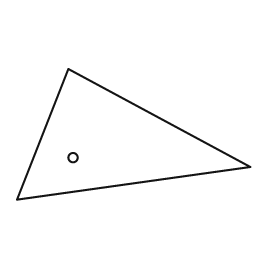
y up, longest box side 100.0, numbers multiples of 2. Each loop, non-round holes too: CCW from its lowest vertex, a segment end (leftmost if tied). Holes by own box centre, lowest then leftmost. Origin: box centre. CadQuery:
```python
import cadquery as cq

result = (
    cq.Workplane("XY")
    .moveTo(-50.0, -28.0)
    .lineTo(50.0, -14.0)
    .lineTo(-28.0, 28.0)
    .close()
    .moveTo(-26.0, -10.0)
    .circle(2.0)
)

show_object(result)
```